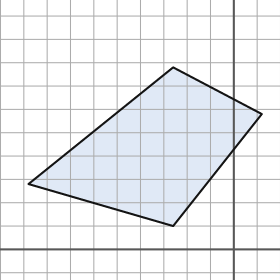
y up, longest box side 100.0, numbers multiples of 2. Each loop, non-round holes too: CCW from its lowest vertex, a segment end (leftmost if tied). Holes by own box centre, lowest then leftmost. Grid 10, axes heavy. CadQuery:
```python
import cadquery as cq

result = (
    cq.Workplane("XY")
    .moveTo(-26.0, 10.0)
    .lineTo(12.0, 58.0)
    .lineTo(-26.0, 78.0)
    .lineTo(-88.0, 28.0)
    .close()
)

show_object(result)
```